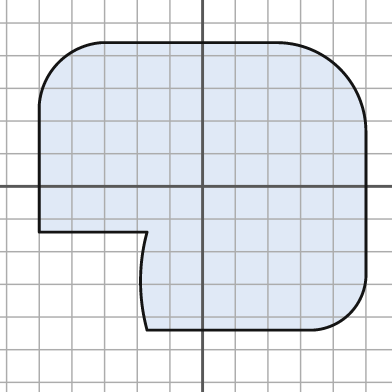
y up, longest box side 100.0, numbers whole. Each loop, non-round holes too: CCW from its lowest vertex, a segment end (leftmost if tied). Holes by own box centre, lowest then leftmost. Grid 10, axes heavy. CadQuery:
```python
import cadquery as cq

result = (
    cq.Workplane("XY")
    .moveTo(-17.0, -44.0)
    .lineTo(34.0, -44.0)
    .threePointArc((45.0, -39.0), (50.0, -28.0))
    .lineTo(50.0, 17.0)
    .threePointArc((42.0, 36.0), (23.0, 44.0))
    .lineTo(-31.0, 44.0)
    .threePointArc((-44.0, 38.0), (-50.0, 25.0))
    .lineTo(-50.0, -14.0)
    .lineTo(-17.0, -14.0)
    .threePointArc((-19.0, -29.0), (-17.0, -44.0))
    .close()
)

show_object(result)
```